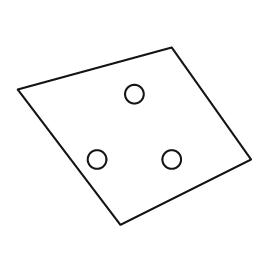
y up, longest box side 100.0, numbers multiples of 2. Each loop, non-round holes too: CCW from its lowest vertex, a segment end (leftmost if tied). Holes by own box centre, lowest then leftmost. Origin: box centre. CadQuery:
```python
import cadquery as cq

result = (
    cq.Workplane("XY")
    .moveTo(-6.0, -38.0)
    .lineTo(50.0, -10.0)
    .lineTo(16.0, 38.0)
    .lineTo(-50.0, 20.0)
    .close()
    .moveTo(-16.0, -10.0)
    .circle(4.0)
    .moveTo(16.0, -10.0)
    .circle(4.0)
    .moveTo(0.0, 18.0)
    .circle(4.0)
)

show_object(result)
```